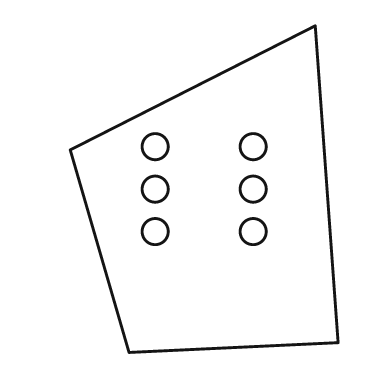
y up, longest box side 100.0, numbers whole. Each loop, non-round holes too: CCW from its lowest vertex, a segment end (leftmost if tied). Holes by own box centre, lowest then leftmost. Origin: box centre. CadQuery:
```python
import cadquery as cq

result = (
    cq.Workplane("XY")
    .moveTo(-23.0, -50.0)
    .lineTo(41.0, -47.0)
    .lineTo(34.0, 50.0)
    .lineTo(-41.0, 12.0)
    .close()
    .moveTo(-15.0, -13.0)
    .circle(4.0)
    .moveTo(15.0, -13.0)
    .circle(4.0)
    .moveTo(-15.0, 0.0)
    .circle(4.0)
    .moveTo(15.0, 0.0)
    .circle(4.0)
    .moveTo(-15.0, 13.0)
    .circle(4.0)
    .moveTo(15.0, 13.0)
    .circle(4.0)
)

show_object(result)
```